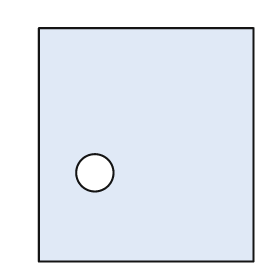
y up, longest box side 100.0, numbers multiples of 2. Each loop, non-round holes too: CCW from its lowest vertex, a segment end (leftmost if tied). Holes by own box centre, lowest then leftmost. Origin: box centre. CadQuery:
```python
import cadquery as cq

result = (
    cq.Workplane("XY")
    .moveTo(-46.0, -50.0)
    .lineTo(46.0, -50.0)
    .lineTo(46.0, 50.0)
    .lineTo(-46.0, 50.0)
    .close()
    .moveTo(-22.0, -12.0)
    .circle(8.0)
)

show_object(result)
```